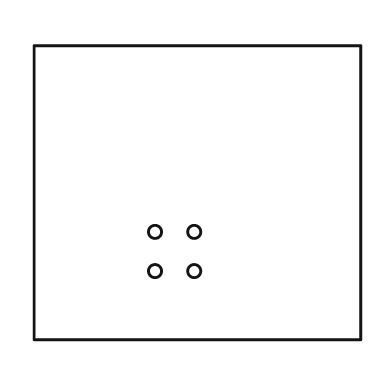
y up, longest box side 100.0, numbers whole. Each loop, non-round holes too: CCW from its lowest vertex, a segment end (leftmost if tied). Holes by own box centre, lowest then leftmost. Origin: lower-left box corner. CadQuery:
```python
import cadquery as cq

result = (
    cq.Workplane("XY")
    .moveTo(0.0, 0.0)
    .lineTo(100.0, 0.0)
    .lineTo(100.0, 90.0)
    .lineTo(0.0, 90.0)
    .close()
    .moveTo(37.0, 21.0)
    .circle(2.0)
    .moveTo(49.0, 21.0)
    .circle(2.0)
    .moveTo(37.0, 33.0)
    .circle(2.0)
    .moveTo(49.0, 33.0)
    .circle(2.0)
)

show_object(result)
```